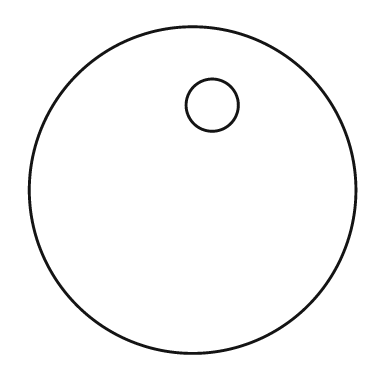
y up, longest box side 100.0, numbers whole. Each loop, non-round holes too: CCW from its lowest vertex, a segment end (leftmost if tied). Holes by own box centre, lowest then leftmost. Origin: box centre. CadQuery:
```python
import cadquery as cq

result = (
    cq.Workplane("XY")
    .moveTo(0.0, 0.0)
    .circle(50.0)
    .moveTo(6.0, 26.0)
    .circle(8.0)
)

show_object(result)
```